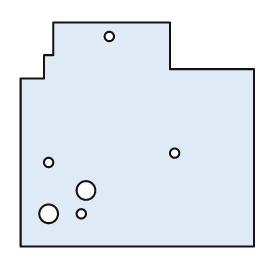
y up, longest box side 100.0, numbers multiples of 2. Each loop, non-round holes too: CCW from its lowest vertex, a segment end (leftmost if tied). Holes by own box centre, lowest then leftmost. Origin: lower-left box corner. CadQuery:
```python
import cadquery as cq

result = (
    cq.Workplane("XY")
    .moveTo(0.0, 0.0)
    .lineTo(100.0, 0.0)
    .lineTo(100.0, 76.0)
    .lineTo(64.0, 76.0)
    .lineTo(64.0, 96.0)
    .lineTo(14.0, 96.0)
    .lineTo(14.0, 82.0)
    .lineTo(10.0, 82.0)
    .lineTo(10.0, 72.0)
    .lineTo(0.0, 72.0)
    .close()
    .moveTo(12.0, 14.0)
    .circle(4.0)
    .moveTo(26.0, 14.0)
    .circle(2.0)
    .moveTo(28.0, 24.0)
    .circle(4.0)
    .moveTo(12.0, 36.0)
    .circle(2.0)
    .moveTo(66.0, 40.0)
    .circle(2.0)
    .moveTo(38.0, 90.0)
    .circle(2.0)
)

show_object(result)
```